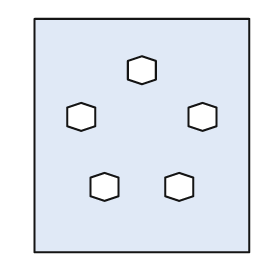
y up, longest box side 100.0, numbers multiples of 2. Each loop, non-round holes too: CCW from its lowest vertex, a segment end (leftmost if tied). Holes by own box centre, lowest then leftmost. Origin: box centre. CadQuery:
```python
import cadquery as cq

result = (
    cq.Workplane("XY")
    .moveTo(-46.0, -50.0)
    .lineTo(46.0, -50.0)
    .lineTo(46.0, 50.0)
    .lineTo(-46.0, 50.0)
    .close()
    .moveTo(-16.0, -28.0)
    .lineTo(-10.0, -26.0)
    .lineTo(-10.0, -18.0)
    .lineTo(-16.0, -16.0)
    .lineTo(-22.0, -18.0)
    .lineTo(-22.0, -26.0)
    .close()
    .moveTo(16.0, -28.0)
    .lineTo(22.0, -26.0)
    .lineTo(22.0, -18.0)
    .lineTo(16.0, -16.0)
    .lineTo(10.0, -18.0)
    .lineTo(10.0, -26.0)
    .close()
    .moveTo(-26.0, 2.0)
    .lineTo(-20.0, 4.0)
    .lineTo(-20.0, 12.0)
    .lineTo(-26.0, 14.0)
    .lineTo(-32.0, 12.0)
    .lineTo(-32.0, 4.0)
    .close()
    .moveTo(26.0, 2.0)
    .lineTo(32.0, 4.0)
    .lineTo(32.0, 12.0)
    .lineTo(26.0, 14.0)
    .lineTo(20.0, 12.0)
    .lineTo(20.0, 4.0)
    .close()
    .moveTo(0.0, 22.0)
    .lineTo(6.0, 24.0)
    .lineTo(6.0, 32.0)
    .lineTo(0.0, 34.0)
    .lineTo(-6.0, 32.0)
    .lineTo(-6.0, 24.0)
    .close()
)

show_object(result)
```